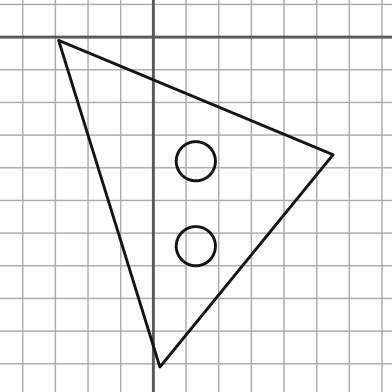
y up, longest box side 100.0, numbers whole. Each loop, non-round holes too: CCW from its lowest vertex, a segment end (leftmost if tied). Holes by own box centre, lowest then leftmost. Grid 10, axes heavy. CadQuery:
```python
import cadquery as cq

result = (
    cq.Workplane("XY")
    .moveTo(2.0, -101.0)
    .lineTo(55.0, -36.0)
    .lineTo(-29.0, -1.0)
    .close()
    .moveTo(13.0, -64.0)
    .circle(6.0)
    .moveTo(13.0, -38.0)
    .circle(6.0)
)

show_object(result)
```